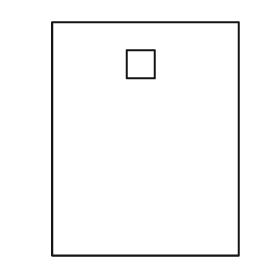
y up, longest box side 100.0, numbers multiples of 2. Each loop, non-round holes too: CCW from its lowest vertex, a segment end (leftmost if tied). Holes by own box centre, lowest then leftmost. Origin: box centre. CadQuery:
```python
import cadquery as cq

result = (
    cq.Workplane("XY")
    .moveTo(-40.0, -50.0)
    .lineTo(40.0, -50.0)
    .lineTo(40.0, 50.0)
    .lineTo(-40.0, 50.0)
    .close()
    .moveTo(-8.0, 26.0)
    .lineTo(4.0, 26.0)
    .lineTo(4.0, 38.0)
    .lineTo(-8.0, 38.0)
    .close()
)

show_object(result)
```